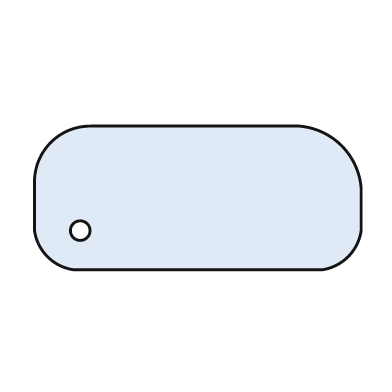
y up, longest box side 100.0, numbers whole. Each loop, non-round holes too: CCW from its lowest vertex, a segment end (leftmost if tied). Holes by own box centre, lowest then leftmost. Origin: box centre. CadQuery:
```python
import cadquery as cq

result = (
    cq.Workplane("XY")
    .moveTo(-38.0, -22.0)
    .lineTo(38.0, -22.0)
    .threePointArc((46.0, -18.0), (50.0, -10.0))
    .lineTo(50.0, 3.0)
    .threePointArc((44.0, 16.0), (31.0, 22.0))
    .lineTo(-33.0, 22.0)
    .threePointArc((-45.0, 17.0), (-50.0, 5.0))
    .lineTo(-50.0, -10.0)
    .threePointArc((-46.0, -18.0), (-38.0, -22.0))
    .close()
    .moveTo(-36.0, -10.0)
    .circle(3.0)
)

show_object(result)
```